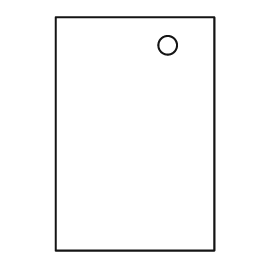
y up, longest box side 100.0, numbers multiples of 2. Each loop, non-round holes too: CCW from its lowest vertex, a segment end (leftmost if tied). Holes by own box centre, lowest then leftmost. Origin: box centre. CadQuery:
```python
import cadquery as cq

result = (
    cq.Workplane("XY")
    .moveTo(-34.0, -50.0)
    .lineTo(34.0, -50.0)
    .lineTo(34.0, 50.0)
    .lineTo(-34.0, 50.0)
    .close()
    .moveTo(14.0, 38.0)
    .circle(4.0)
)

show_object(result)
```